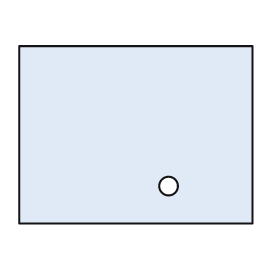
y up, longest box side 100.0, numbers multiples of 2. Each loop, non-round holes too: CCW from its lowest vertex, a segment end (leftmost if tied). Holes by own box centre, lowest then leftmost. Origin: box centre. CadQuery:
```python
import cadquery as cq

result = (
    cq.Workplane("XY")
    .moveTo(-50.0, -38.0)
    .lineTo(50.0, -38.0)
    .lineTo(50.0, 38.0)
    .lineTo(-50.0, 38.0)
    .close()
    .moveTo(14.0, -22.0)
    .circle(4.0)
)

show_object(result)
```